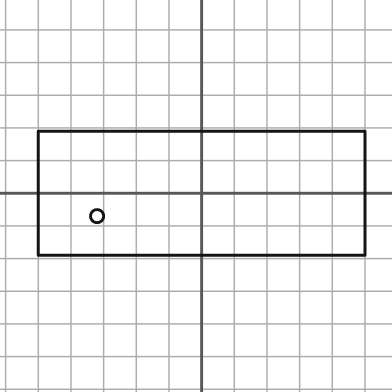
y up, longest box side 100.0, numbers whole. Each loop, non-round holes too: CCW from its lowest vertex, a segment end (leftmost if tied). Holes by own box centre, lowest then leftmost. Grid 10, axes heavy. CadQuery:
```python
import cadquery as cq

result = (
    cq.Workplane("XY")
    .moveTo(-50.0, -19.0)
    .lineTo(50.0, -19.0)
    .lineTo(50.0, 19.0)
    .lineTo(-50.0, 19.0)
    .close()
    .moveTo(-32.0, -7.0)
    .circle(2.0)
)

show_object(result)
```